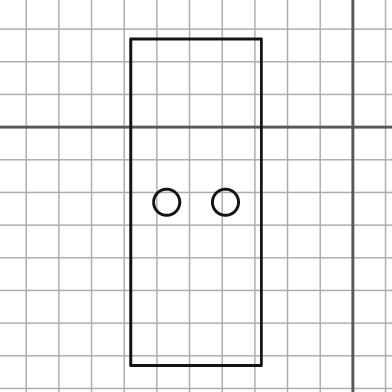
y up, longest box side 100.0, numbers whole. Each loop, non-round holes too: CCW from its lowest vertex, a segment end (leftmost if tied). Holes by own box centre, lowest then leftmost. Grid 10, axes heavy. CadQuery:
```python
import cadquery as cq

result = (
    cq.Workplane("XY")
    .moveTo(-68.0, -73.0)
    .lineTo(-28.0, -73.0)
    .lineTo(-28.0, 27.0)
    .lineTo(-68.0, 27.0)
    .close()
    .moveTo(-57.0, -23.0)
    .circle(4.0)
    .moveTo(-39.0, -23.0)
    .circle(4.0)
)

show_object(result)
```